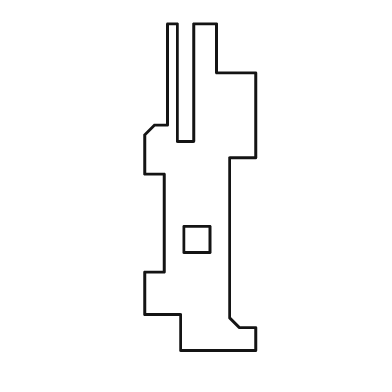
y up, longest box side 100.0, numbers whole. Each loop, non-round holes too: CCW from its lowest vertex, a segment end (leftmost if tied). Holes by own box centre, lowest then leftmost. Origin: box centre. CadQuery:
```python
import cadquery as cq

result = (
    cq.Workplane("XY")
    .moveTo(-6.0, -50.0)
    .lineTo(17.0, -50.0)
    .lineTo(17.0, -43.0)
    .lineTo(12.0, -43.0)
    .lineTo(9.0, -40.0)
    .lineTo(9.0, 9.0)
    .lineTo(17.0, 9.0)
    .lineTo(17.0, 35.0)
    .lineTo(5.0, 35.0)
    .lineTo(5.0, 50.0)
    .lineTo(-2.0, 50.0)
    .lineTo(-2.0, 14.0)
    .lineTo(-7.0, 14.0)
    .lineTo(-7.0, 50.0)
    .lineTo(-10.0, 50.0)
    .lineTo(-10.0, 19.0)
    .lineTo(-14.0, 19.0)
    .lineTo(-17.0, 16.0)
    .lineTo(-17.0, 4.0)
    .lineTo(-11.0, 4.0)
    .lineTo(-11.0, -26.0)
    .lineTo(-17.0, -26.0)
    .lineTo(-17.0, -39.0)
    .lineTo(-6.0, -39.0)
    .close()
    .moveTo(-5.0, -20.0)
    .lineTo(3.0, -20.0)
    .lineTo(3.0, -12.0)
    .lineTo(-5.0, -12.0)
    .close()
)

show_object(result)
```